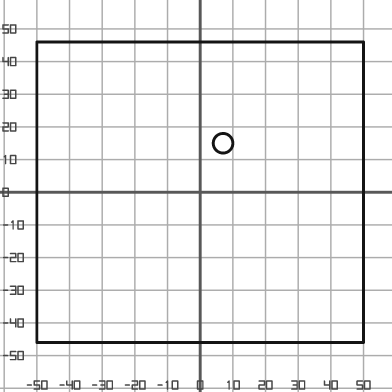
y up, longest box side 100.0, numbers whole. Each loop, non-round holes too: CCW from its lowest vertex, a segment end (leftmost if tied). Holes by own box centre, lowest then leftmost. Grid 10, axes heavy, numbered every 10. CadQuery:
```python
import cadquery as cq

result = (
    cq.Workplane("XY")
    .moveTo(-50.0, -46.0)
    .lineTo(50.0, -46.0)
    .lineTo(50.0, 46.0)
    .lineTo(-50.0, 46.0)
    .close()
    .moveTo(7.0, 15.0)
    .circle(3.0)
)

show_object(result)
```